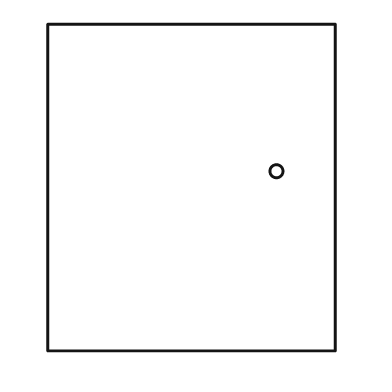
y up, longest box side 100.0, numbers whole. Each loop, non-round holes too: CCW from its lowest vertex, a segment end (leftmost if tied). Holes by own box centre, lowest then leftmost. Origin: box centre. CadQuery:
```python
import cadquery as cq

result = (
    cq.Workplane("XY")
    .moveTo(-44.0, -50.0)
    .lineTo(44.0, -50.0)
    .lineTo(44.0, 50.0)
    .lineTo(-44.0, 50.0)
    .close()
    .moveTo(26.0, 5.0)
    .circle(2.0)
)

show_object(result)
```